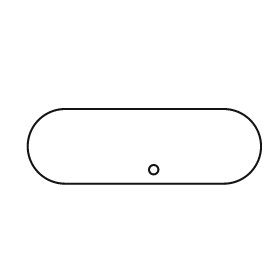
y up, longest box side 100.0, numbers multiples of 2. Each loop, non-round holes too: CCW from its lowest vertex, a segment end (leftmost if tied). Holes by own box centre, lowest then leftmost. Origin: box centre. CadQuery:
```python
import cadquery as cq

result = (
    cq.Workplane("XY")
    .moveTo(-34.0, -16.0)
    .lineTo(34.0, -16.0)
    .threePointArc((50.0, 0.0), (34.0, 16.0))
    .lineTo(-34.0, 16.0)
    .threePointArc((-50.0, 0.0), (-34.0, -16.0))
    .close()
    .moveTo(4.0, -10.0)
    .circle(2.0)
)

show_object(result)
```